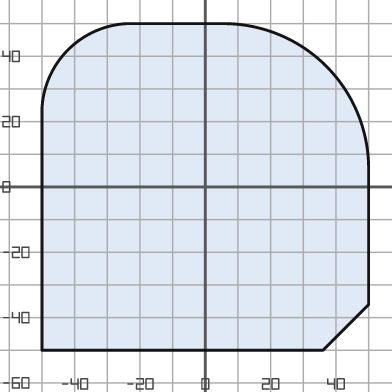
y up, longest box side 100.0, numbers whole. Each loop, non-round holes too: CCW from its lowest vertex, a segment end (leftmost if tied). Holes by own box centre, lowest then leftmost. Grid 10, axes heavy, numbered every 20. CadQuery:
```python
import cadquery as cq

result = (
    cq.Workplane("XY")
    .moveTo(-50.0, -50.0)
    .lineTo(36.0, -50.0)
    .lineTo(50.0, -36.0)
    .lineTo(50.0, 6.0)
    .threePointArc((37.0, 37.0), (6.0, 50.0))
    .lineTo(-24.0, 50.0)
    .threePointArc((-42.0, 42.0), (-50.0, 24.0))
    .close()
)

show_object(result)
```